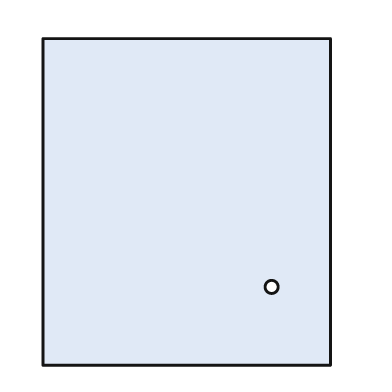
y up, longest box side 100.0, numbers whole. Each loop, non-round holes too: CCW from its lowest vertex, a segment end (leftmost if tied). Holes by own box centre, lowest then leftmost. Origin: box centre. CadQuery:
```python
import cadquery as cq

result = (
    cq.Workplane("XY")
    .moveTo(-44.0, -50.0)
    .lineTo(44.0, -50.0)
    .lineTo(44.0, 50.0)
    .lineTo(-44.0, 50.0)
    .close()
    .moveTo(26.0, -26.0)
    .circle(2.0)
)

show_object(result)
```